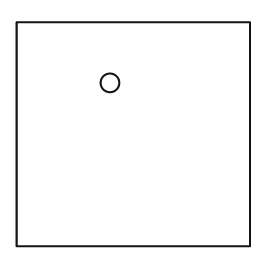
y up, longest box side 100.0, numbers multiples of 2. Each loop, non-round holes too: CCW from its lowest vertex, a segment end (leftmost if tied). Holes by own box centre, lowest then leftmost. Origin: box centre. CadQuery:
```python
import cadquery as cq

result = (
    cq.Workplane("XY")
    .moveTo(-50.0, -48.0)
    .lineTo(50.0, -48.0)
    .lineTo(50.0, 48.0)
    .lineTo(-50.0, 48.0)
    .close()
    .moveTo(-10.0, 22.0)
    .circle(4.0)
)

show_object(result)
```